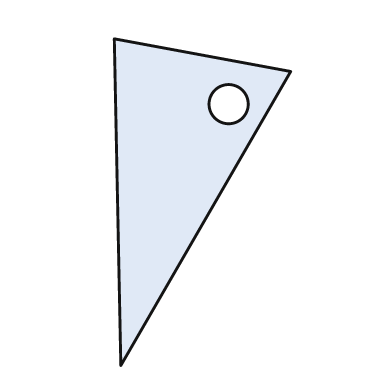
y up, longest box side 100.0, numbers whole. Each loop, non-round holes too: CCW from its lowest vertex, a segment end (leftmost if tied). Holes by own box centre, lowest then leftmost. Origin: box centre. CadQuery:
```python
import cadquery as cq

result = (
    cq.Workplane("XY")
    .moveTo(-25.0, -50.0)
    .lineTo(27.0, 40.0)
    .lineTo(-27.0, 50.0)
    .close()
    .moveTo(8.0, 30.0)
    .circle(6.0)
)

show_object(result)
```